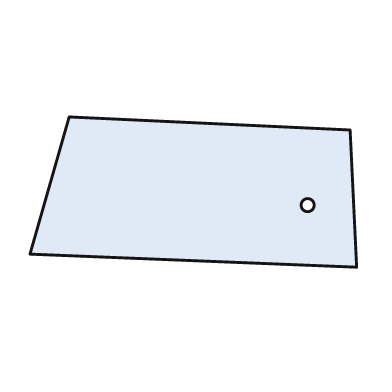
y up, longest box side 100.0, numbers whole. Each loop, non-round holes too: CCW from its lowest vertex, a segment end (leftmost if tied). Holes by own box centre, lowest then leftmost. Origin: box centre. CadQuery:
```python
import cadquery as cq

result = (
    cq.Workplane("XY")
    .moveTo(50.0, -23.0)
    .lineTo(48.0, 19.0)
    .lineTo(-38.0, 23.0)
    .lineTo(-50.0, -19.0)
    .close()
    .moveTo(35.0, -4.0)
    .circle(2.0)
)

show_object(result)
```